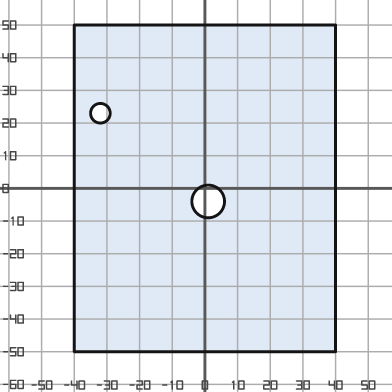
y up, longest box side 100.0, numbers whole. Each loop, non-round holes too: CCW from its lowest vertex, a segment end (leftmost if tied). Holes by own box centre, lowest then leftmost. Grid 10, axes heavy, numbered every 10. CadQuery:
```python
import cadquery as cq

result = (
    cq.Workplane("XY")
    .moveTo(-40.0, -50.0)
    .lineTo(40.0, -50.0)
    .lineTo(40.0, 50.0)
    .lineTo(-40.0, 50.0)
    .close()
    .moveTo(1.0, -4.0)
    .circle(5.0)
    .moveTo(-32.0, 23.0)
    .circle(3.0)
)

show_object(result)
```